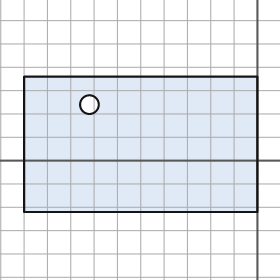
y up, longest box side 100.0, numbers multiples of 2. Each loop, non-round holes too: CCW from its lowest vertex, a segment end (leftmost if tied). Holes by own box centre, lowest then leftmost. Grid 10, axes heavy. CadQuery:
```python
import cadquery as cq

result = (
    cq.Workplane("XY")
    .moveTo(-100.0, -22.0)
    .lineTo(0.0, -22.0)
    .lineTo(0.0, 36.0)
    .lineTo(-100.0, 36.0)
    .close()
    .moveTo(-72.0, 24.0)
    .circle(4.0)
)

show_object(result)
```